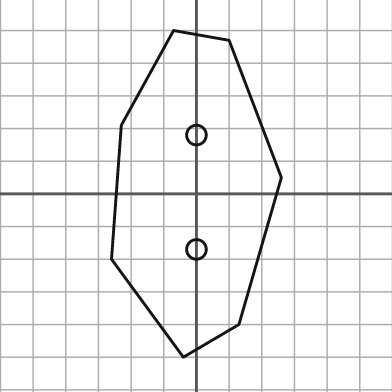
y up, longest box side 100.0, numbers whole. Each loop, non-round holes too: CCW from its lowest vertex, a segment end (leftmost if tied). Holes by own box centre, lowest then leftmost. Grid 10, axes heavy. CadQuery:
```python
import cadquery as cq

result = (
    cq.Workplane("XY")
    .moveTo(-4.0, -50.0)
    .lineTo(13.0, -40.0)
    .lineTo(26.0, 5.0)
    .lineTo(10.0, 47.0)
    .lineTo(-7.0, 50.0)
    .lineTo(-23.0, 21.0)
    .lineTo(-26.0, -20.0)
    .close()
    .moveTo(0.0, -17.0)
    .circle(3.0)
    .moveTo(0.0, 18.0)
    .circle(3.0)
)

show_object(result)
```